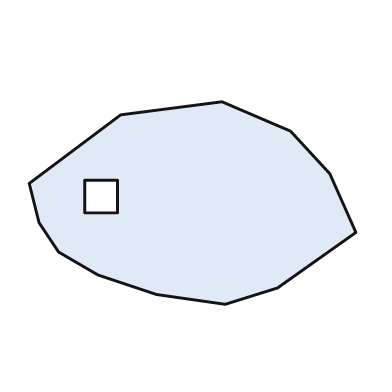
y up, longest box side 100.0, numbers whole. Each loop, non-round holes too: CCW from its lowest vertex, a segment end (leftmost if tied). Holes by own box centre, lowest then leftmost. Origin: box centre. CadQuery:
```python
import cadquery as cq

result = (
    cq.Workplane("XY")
    .moveTo(10.0, -31.0)
    .lineTo(26.0, -26.0)
    .lineTo(50.0, -9.0)
    .lineTo(42.0, 9.0)
    .lineTo(30.0, 22.0)
    .lineTo(9.0, 31.0)
    .lineTo(-22.0, 27.0)
    .lineTo(-50.0, 6.0)
    .lineTo(-47.0, -6.0)
    .lineTo(-41.0, -15.0)
    .lineTo(-29.0, -22.0)
    .lineTo(-11.0, -28.0)
    .close()
    .moveTo(-33.0, -3.0)
    .lineTo(-23.0, -3.0)
    .lineTo(-23.0, 7.0)
    .lineTo(-33.0, 7.0)
    .close()
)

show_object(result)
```